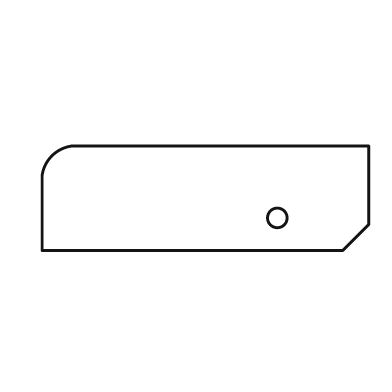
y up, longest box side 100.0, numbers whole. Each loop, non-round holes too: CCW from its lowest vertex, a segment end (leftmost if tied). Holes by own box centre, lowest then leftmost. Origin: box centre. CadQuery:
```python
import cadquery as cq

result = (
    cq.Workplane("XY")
    .moveTo(-50.0, -16.0)
    .lineTo(42.0, -16.0)
    .lineTo(50.0, -8.0)
    .lineTo(50.0, 16.0)
    .lineTo(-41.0, 16.0)
    .threePointArc((-47.0, 13.0), (-50.0, 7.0))
    .close()
    .moveTo(22.0, -6.0)
    .circle(3.0)
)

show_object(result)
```